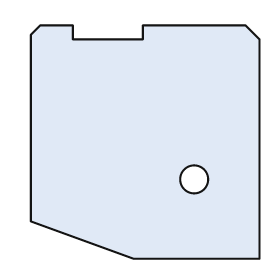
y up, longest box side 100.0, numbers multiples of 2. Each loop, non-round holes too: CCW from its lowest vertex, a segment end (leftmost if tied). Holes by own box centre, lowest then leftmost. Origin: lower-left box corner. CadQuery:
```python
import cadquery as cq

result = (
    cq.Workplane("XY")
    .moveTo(44.0, 0.0)
    .lineTo(98.0, 0.0)
    .lineTo(98.0, 94.0)
    .lineTo(92.0, 100.0)
    .lineTo(48.0, 100.0)
    .lineTo(48.0, 94.0)
    .lineTo(18.0, 94.0)
    .lineTo(18.0, 100.0)
    .lineTo(4.0, 100.0)
    .lineTo(0.0, 96.0)
    .lineTo(0.0, 16.0)
    .close()
    .moveTo(70.0, 34.0)
    .circle(6.0)
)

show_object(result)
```